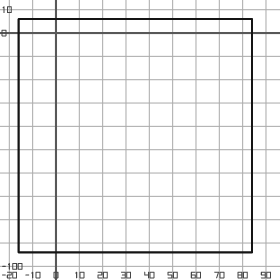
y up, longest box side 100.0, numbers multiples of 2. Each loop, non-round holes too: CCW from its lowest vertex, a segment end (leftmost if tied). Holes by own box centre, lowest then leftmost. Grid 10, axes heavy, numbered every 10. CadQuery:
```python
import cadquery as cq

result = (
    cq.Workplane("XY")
    .moveTo(-16.0, -94.0)
    .lineTo(84.0, -94.0)
    .lineTo(84.0, 6.0)
    .lineTo(-16.0, 6.0)
    .close()
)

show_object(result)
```